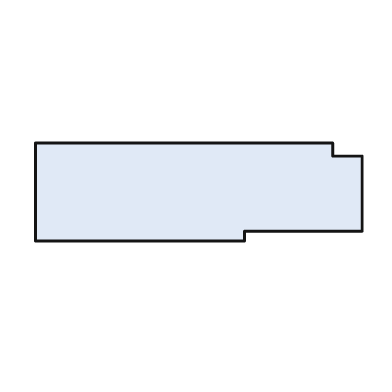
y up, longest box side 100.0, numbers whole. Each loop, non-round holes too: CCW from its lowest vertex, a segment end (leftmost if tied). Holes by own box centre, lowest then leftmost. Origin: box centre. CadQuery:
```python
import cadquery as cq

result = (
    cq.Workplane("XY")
    .moveTo(-50.0, -15.0)
    .lineTo(14.0, -15.0)
    .lineTo(14.0, -12.0)
    .lineTo(50.0, -12.0)
    .lineTo(50.0, 11.0)
    .lineTo(41.0, 11.0)
    .lineTo(41.0, 15.0)
    .lineTo(-50.0, 15.0)
    .close()
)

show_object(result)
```